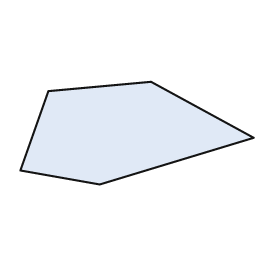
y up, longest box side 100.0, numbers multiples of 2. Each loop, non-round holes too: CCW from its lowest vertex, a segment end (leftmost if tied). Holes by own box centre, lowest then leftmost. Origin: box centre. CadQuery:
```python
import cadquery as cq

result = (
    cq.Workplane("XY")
    .moveTo(-16.0, -22.0)
    .lineTo(50.0, -2.0)
    .lineTo(6.0, 22.0)
    .lineTo(-38.0, 18.0)
    .lineTo(-50.0, -16.0)
    .close()
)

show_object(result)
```